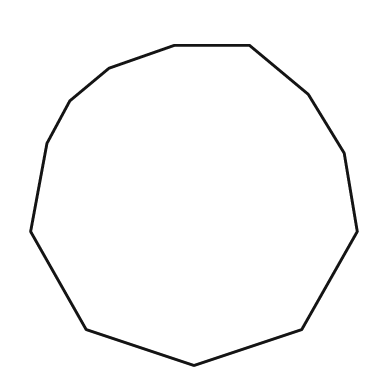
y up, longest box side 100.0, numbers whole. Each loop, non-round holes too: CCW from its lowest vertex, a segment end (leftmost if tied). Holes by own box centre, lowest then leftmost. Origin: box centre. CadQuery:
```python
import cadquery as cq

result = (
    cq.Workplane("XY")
    .moveTo(0.0, -49.0)
    .lineTo(33.0, -38.0)
    .lineTo(50.0, -8.0)
    .lineTo(46.0, 16.0)
    .lineTo(35.0, 34.0)
    .lineTo(17.0, 49.0)
    .lineTo(-6.0, 49.0)
    .lineTo(-26.0, 42.0)
    .lineTo(-38.0, 32.0)
    .lineTo(-45.0, 19.0)
    .lineTo(-50.0, -8.0)
    .lineTo(-33.0, -38.0)
    .close()
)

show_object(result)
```